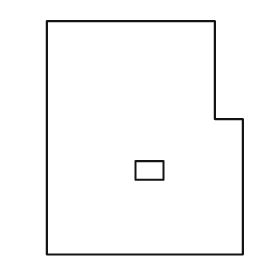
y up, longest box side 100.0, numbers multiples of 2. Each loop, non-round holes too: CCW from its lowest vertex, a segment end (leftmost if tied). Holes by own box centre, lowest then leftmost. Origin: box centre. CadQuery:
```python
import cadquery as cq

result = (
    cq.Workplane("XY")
    .moveTo(-42.0, -50.0)
    .lineTo(42.0, -50.0)
    .lineTo(42.0, 8.0)
    .lineTo(30.0, 8.0)
    .lineTo(30.0, 50.0)
    .lineTo(-42.0, 50.0)
    .close()
    .moveTo(-4.0, -18.0)
    .lineTo(8.0, -18.0)
    .lineTo(8.0, -10.0)
    .lineTo(-4.0, -10.0)
    .close()
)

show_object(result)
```